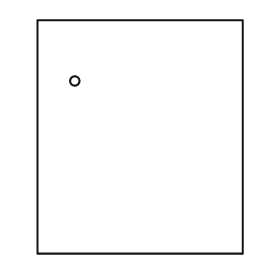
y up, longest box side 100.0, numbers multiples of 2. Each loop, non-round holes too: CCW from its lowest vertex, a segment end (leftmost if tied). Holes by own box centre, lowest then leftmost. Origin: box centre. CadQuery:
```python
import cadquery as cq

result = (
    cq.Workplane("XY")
    .moveTo(-44.0, -50.0)
    .lineTo(44.0, -50.0)
    .lineTo(44.0, 50.0)
    .lineTo(-44.0, 50.0)
    .close()
    .moveTo(-28.0, 24.0)
    .circle(2.0)
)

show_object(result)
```